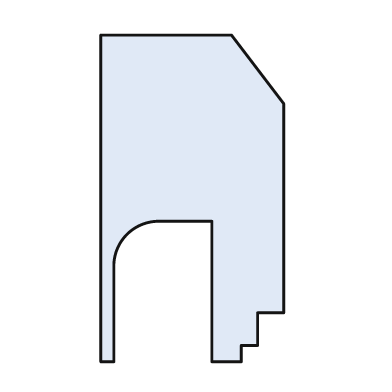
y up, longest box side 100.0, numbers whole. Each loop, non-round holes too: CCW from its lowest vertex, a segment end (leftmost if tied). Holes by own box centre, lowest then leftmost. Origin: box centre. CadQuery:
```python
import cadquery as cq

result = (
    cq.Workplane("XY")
    .moveTo(-28.0, -50.0)
    .lineTo(-24.0, -50.0)
    .lineTo(-24.0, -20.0)
    .threePointArc((-20.0, -11.0), (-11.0, -7.0))
    .lineTo(6.0, -7.0)
    .lineTo(6.0, -50.0)
    .lineTo(15.0, -50.0)
    .lineTo(15.0, -45.0)
    .lineTo(20.0, -45.0)
    .lineTo(20.0, -35.0)
    .lineTo(28.0, -35.0)
    .lineTo(28.0, 29.0)
    .lineTo(12.0, 50.0)
    .lineTo(-28.0, 50.0)
    .close()
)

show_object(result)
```